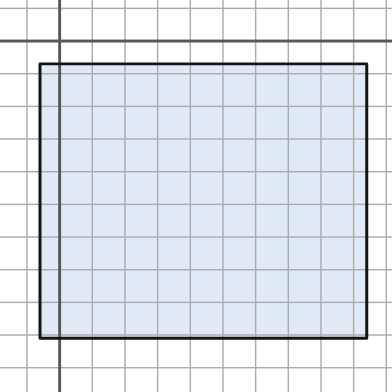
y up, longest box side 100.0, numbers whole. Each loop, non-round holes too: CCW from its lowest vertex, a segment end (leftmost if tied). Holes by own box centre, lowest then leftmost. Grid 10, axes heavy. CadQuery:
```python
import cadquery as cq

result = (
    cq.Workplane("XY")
    .moveTo(-6.0, -91.0)
    .lineTo(94.0, -91.0)
    .lineTo(94.0, -7.0)
    .lineTo(-6.0, -7.0)
    .close()
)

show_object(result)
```